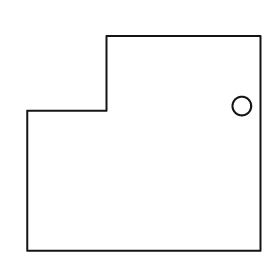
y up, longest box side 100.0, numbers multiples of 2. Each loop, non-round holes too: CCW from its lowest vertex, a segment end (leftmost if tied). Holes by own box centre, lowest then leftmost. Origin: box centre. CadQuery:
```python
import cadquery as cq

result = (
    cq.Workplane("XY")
    .moveTo(-50.0, -46.0)
    .lineTo(50.0, -46.0)
    .lineTo(50.0, 46.0)
    .lineTo(-16.0, 46.0)
    .lineTo(-16.0, 14.0)
    .lineTo(-50.0, 14.0)
    .close()
    .moveTo(42.0, 16.0)
    .circle(4.0)
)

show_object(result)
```